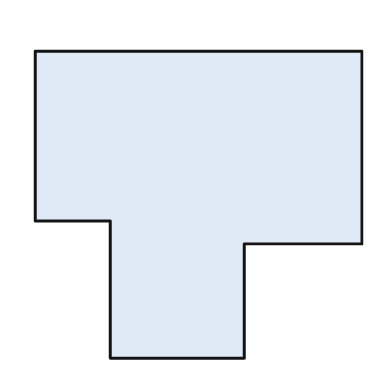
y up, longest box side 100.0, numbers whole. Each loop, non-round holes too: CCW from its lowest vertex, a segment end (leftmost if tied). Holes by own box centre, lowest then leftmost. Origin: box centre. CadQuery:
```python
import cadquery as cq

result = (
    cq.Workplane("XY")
    .moveTo(-27.0, -47.0)
    .lineTo(14.0, -47.0)
    .lineTo(14.0, -12.0)
    .lineTo(50.0, -12.0)
    .lineTo(50.0, 47.0)
    .lineTo(-50.0, 47.0)
    .lineTo(-50.0, -5.0)
    .lineTo(-27.0, -5.0)
    .close()
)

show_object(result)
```